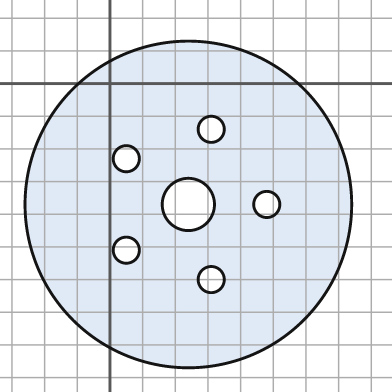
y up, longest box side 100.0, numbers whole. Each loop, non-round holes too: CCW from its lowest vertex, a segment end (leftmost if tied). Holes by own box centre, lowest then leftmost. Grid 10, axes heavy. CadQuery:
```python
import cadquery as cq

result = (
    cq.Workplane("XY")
    .moveTo(24.0, -37.0)
    .circle(50.0)
    .moveTo(31.0, -60.0)
    .circle(4.0)
    .moveTo(5.0, -51.0)
    .circle(4.0)
    .moveTo(24.0, -37.0)
    .circle(8.0)
    .moveTo(48.0, -37.0)
    .circle(4.0)
    .moveTo(5.0, -23.0)
    .circle(4.0)
    .moveTo(31.0, -14.0)
    .circle(4.0)
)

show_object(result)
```